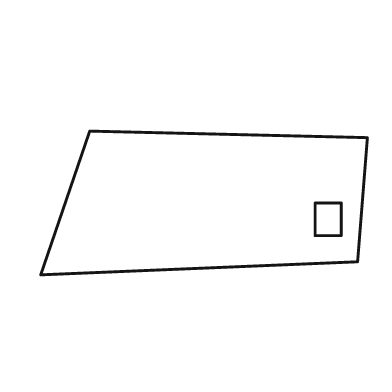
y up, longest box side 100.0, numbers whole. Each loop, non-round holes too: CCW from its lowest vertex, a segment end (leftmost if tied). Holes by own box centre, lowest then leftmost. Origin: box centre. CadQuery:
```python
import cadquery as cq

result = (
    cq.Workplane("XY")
    .moveTo(-50.0, -22.0)
    .lineTo(47.0, -18.0)
    .lineTo(50.0, 20.0)
    .lineTo(-35.0, 22.0)
    .close()
    .moveTo(34.0, -10.0)
    .lineTo(42.0, -10.0)
    .lineTo(42.0, 0.0)
    .lineTo(34.0, 0.0)
    .close()
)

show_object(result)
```